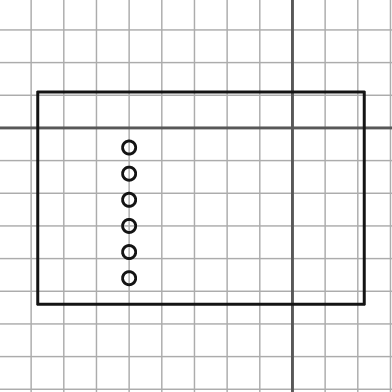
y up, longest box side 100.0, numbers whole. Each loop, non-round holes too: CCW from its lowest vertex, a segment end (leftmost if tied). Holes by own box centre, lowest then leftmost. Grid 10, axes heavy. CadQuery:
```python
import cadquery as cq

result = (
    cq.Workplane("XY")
    .moveTo(-78.0, -54.0)
    .lineTo(22.0, -54.0)
    .lineTo(22.0, 11.0)
    .lineTo(-78.0, 11.0)
    .close()
    .moveTo(-50.0, -46.0)
    .circle(2.0)
    .moveTo(-50.0, -38.0)
    .circle(2.0)
    .moveTo(-50.0, -30.0)
    .circle(2.0)
    .moveTo(-50.0, -22.0)
    .circle(2.0)
    .moveTo(-50.0, -14.0)
    .circle(2.0)
    .moveTo(-50.0, -6.0)
    .circle(2.0)
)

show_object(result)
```